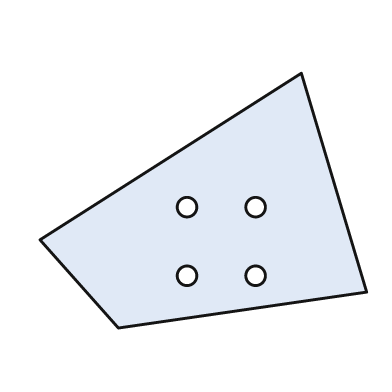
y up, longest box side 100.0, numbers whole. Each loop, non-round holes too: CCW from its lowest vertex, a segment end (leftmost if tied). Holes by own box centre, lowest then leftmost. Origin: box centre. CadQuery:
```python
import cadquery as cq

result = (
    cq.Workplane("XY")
    .moveTo(-26.0, -39.0)
    .lineTo(50.0, -28.0)
    .lineTo(30.0, 39.0)
    .lineTo(-50.0, -12.0)
    .close()
    .moveTo(-5.0, -23.0)
    .circle(3.0)
    .moveTo(16.0, -23.0)
    .circle(3.0)
    .moveTo(-5.0, -2.0)
    .circle(3.0)
    .moveTo(16.0, -2.0)
    .circle(3.0)
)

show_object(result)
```